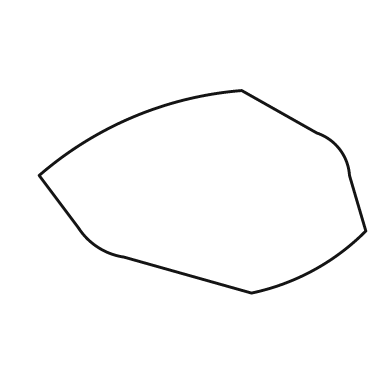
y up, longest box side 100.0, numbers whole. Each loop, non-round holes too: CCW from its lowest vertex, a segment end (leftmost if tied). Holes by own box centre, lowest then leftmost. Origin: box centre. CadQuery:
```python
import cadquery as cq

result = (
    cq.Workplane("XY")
    .moveTo(15.0, -31.0)
    .threePointArc((34.0, -24.0), (50.0, -12.0))
    .lineTo(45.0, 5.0)
    .threePointArc((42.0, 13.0), (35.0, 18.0))
    .lineTo(12.0, 31.0)
    .threePointArc((-21.0, 23.0), (-50.0, 5.0))
    .lineTo(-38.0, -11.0)
    .threePointArc((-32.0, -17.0), (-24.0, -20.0))
    .close()
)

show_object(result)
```